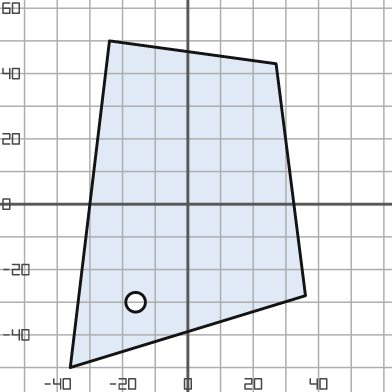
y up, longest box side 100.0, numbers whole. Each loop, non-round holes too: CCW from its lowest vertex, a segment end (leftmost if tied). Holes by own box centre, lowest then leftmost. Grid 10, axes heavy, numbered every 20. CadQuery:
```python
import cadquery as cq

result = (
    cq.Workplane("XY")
    .moveTo(-36.0, -50.0)
    .lineTo(36.0, -28.0)
    .lineTo(27.0, 43.0)
    .lineTo(-24.0, 50.0)
    .close()
    .moveTo(-16.0, -30.0)
    .circle(3.0)
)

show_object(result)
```